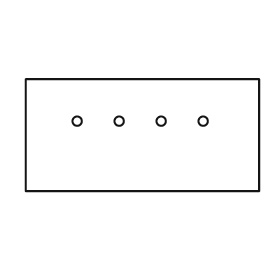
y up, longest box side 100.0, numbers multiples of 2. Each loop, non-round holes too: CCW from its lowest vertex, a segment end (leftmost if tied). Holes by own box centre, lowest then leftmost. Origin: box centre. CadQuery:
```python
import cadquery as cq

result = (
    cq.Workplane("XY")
    .moveTo(-50.0, -24.0)
    .lineTo(50.0, -24.0)
    .lineTo(50.0, 24.0)
    .lineTo(-50.0, 24.0)
    .close()
    .moveTo(-28.0, 6.0)
    .circle(2.0)
    .moveTo(-10.0, 6.0)
    .circle(2.0)
    .moveTo(8.0, 6.0)
    .circle(2.0)
    .moveTo(26.0, 6.0)
    .circle(2.0)
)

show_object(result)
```